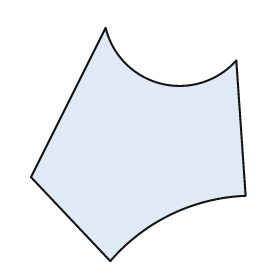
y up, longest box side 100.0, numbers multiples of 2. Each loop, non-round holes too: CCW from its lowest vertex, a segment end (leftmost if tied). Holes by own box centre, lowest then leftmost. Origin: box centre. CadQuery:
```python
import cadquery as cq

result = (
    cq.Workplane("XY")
    .moveTo(-12.0, -50.0)
    .threePointArc((14.0, -30.0), (46.0, -22.0))
    .lineTo(42.0, 36.0)
    .threePointArc((10.0, 26.0), (-14.0, 50.0))
    .lineTo(-46.0, -14.0)
    .close()
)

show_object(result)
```